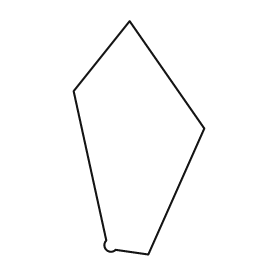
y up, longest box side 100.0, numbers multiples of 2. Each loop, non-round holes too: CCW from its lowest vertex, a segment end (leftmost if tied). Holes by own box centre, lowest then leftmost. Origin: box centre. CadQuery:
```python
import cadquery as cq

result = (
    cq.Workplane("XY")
    .moveTo(4.0, -50.0)
    .lineTo(28.0, 4.0)
    .lineTo(-4.0, 50.0)
    .lineTo(-28.0, 20.0)
    .lineTo(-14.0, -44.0)
    .threePointArc((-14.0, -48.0), (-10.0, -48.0))
    .close()
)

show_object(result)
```